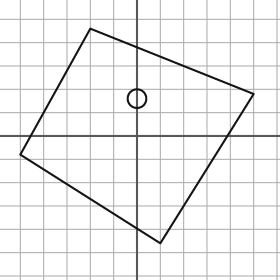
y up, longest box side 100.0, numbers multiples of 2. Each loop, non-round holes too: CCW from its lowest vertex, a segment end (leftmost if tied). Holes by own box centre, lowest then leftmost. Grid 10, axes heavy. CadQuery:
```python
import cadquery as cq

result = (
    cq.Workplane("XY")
    .moveTo(10.0, -46.0)
    .lineTo(50.0, 18.0)
    .lineTo(-20.0, 46.0)
    .lineTo(-50.0, -8.0)
    .close()
    .moveTo(0.0, 16.0)
    .circle(4.0)
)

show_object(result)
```